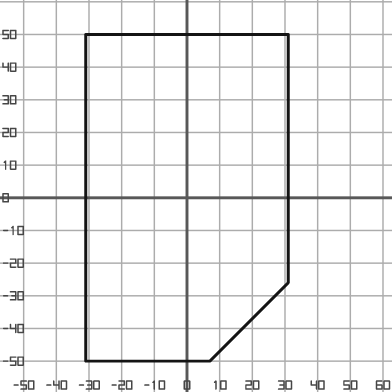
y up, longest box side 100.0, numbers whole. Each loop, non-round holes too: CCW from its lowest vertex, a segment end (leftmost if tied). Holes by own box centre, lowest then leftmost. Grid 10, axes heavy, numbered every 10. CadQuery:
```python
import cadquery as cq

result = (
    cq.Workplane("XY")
    .moveTo(-31.0, -50.0)
    .lineTo(7.0, -50.0)
    .lineTo(31.0, -26.0)
    .lineTo(31.0, 50.0)
    .lineTo(-31.0, 50.0)
    .close()
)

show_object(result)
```